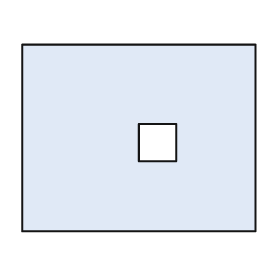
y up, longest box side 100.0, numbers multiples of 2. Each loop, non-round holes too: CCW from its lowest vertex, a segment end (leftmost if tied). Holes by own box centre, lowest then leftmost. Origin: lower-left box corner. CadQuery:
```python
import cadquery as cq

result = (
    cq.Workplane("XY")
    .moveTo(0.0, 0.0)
    .lineTo(100.0, 0.0)
    .lineTo(100.0, 80.0)
    .lineTo(0.0, 80.0)
    .close()
    .moveTo(50.0, 30.0)
    .lineTo(66.0, 30.0)
    .lineTo(66.0, 46.0)
    .lineTo(50.0, 46.0)
    .close()
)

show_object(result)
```